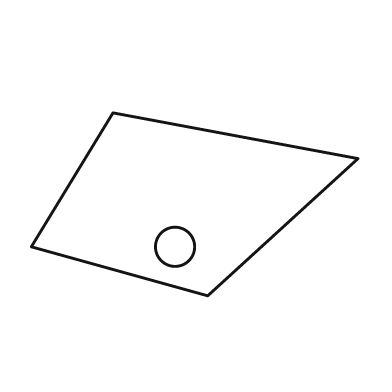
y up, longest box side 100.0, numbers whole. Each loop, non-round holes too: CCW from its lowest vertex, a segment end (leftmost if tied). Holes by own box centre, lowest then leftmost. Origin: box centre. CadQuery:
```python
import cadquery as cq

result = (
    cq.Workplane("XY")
    .moveTo(4.0, -28.0)
    .lineTo(50.0, 14.0)
    .lineTo(-25.0, 28.0)
    .lineTo(-50.0, -13.0)
    .close()
    .moveTo(-6.0, -13.0)
    .circle(6.0)
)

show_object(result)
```